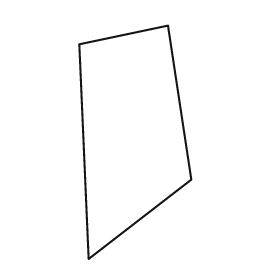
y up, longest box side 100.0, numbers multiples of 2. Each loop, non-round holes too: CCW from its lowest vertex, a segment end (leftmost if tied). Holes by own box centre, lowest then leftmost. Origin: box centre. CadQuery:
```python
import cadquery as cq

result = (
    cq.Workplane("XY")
    .moveTo(-20.0, -50.0)
    .lineTo(24.0, -16.0)
    .lineTo(14.0, 50.0)
    .lineTo(-24.0, 42.0)
    .close()
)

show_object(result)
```